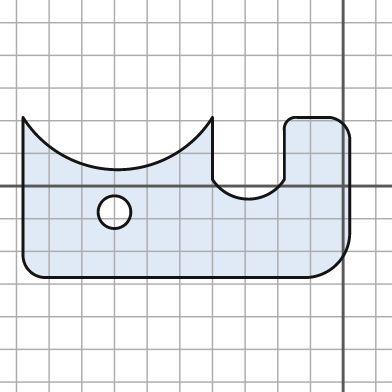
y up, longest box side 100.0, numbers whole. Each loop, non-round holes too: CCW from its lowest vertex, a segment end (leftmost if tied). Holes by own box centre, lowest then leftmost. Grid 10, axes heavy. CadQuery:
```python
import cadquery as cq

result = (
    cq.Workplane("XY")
    .moveTo(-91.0, -28.0)
    .lineTo(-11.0, -28.0)
    .threePointArc((-2.0, -24.0), (2.0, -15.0))
    .lineTo(2.0, 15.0)
    .threePointArc((0.0, 19.0), (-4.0, 21.0))
    .lineTo(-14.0, 21.0)
    .threePointArc((-17.0, 20.0), (-18.0, 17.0))
    .lineTo(-18.0, 2.0)
    .threePointArc((-29.0, -4.0), (-40.0, 2.0))
    .lineTo(-40.0, 21.0)
    .threePointArc((-69.0, 5.0), (-98.0, 21.0))
    .lineTo(-98.0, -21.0)
    .threePointArc((-96.0, -26.0), (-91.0, -28.0))
    .close()
    .moveTo(-70.0, -8.0)
    .circle(5.0)
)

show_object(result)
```